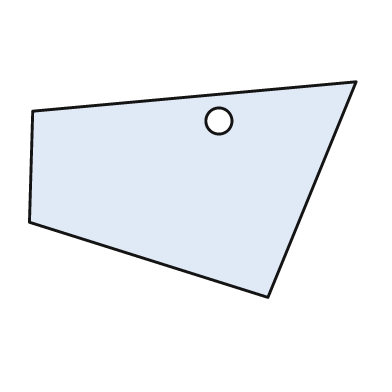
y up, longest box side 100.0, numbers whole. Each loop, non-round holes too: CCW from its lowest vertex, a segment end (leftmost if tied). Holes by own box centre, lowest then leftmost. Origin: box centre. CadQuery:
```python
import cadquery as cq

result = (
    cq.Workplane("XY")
    .moveTo(23.0, -33.0)
    .lineTo(50.0, 33.0)
    .lineTo(-49.0, 24.0)
    .lineTo(-50.0, -10.0)
    .close()
    .moveTo(8.0, 21.0)
    .circle(4.0)
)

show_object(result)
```